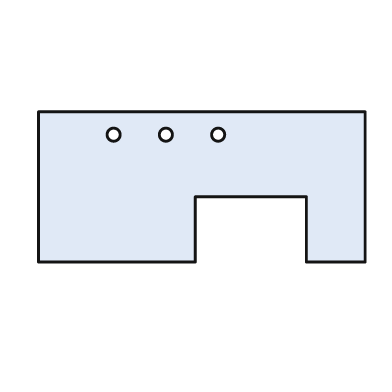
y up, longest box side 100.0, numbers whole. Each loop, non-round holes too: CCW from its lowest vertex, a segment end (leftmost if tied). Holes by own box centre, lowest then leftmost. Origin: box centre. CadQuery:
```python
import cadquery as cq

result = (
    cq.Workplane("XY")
    .moveTo(-50.0, -23.0)
    .lineTo(-2.0, -23.0)
    .lineTo(-2.0, -3.0)
    .lineTo(32.0, -3.0)
    .lineTo(32.0, -23.0)
    .lineTo(50.0, -23.0)
    .lineTo(50.0, 23.0)
    .lineTo(-50.0, 23.0)
    .close()
    .moveTo(-27.0, 16.0)
    .circle(2.0)
    .moveTo(-11.0, 16.0)
    .circle(2.0)
    .moveTo(5.0, 16.0)
    .circle(2.0)
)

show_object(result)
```